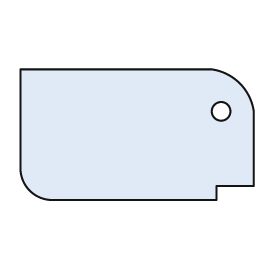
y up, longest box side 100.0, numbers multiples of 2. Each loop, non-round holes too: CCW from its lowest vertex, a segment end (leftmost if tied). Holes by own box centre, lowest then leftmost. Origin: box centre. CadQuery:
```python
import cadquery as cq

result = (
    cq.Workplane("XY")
    .moveTo(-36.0, -28.0)
    .lineTo(34.0, -28.0)
    .lineTo(34.0, -22.0)
    .lineTo(50.0, -22.0)
    .lineTo(50.0, 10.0)
    .threePointArc((44.0, 22.0), (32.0, 28.0))
    .lineTo(-50.0, 28.0)
    .lineTo(-50.0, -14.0)
    .threePointArc((-46.0, -24.0), (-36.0, -28.0))
    .close()
    .moveTo(36.0, 10.0)
    .circle(4.0)
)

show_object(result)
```